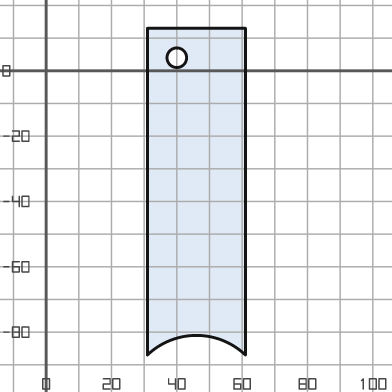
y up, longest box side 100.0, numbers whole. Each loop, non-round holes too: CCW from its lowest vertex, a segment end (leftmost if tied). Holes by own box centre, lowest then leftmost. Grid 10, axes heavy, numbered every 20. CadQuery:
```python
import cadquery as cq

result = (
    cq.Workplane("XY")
    .moveTo(31.0, -87.0)
    .threePointArc((46.0, -81.0), (61.0, -87.0))
    .lineTo(61.0, 13.0)
    .lineTo(31.0, 13.0)
    .close()
    .moveTo(40.0, 4.0)
    .circle(3.0)
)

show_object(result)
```